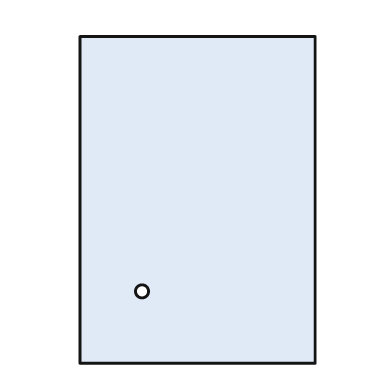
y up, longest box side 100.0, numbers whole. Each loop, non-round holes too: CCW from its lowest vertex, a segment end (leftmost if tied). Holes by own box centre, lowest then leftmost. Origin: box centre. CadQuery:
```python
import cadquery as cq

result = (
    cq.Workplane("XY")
    .moveTo(-36.0, -50.0)
    .lineTo(36.0, -50.0)
    .lineTo(36.0, 50.0)
    .lineTo(-36.0, 50.0)
    .close()
    .moveTo(-17.0, -28.0)
    .circle(2.0)
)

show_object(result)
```